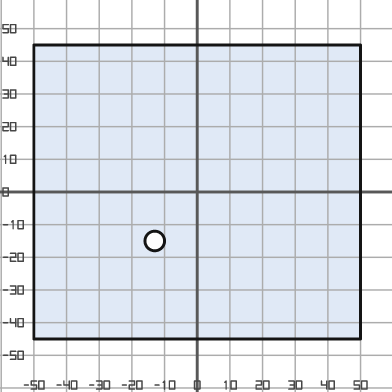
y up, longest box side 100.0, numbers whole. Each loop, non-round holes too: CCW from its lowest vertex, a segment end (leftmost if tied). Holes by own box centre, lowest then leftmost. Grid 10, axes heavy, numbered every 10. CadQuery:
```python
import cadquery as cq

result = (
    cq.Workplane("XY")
    .moveTo(-50.0, -45.0)
    .lineTo(50.0, -45.0)
    .lineTo(50.0, 45.0)
    .lineTo(-50.0, 45.0)
    .close()
    .moveTo(-13.0, -15.0)
    .circle(3.0)
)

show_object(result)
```